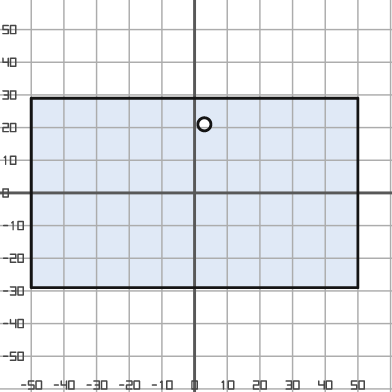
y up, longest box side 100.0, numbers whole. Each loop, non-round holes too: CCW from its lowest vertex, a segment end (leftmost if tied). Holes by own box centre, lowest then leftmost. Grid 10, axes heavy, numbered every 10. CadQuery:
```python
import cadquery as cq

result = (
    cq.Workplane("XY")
    .moveTo(-50.0, -29.0)
    .lineTo(50.0, -29.0)
    .lineTo(50.0, 29.0)
    .lineTo(-50.0, 29.0)
    .close()
    .moveTo(3.0, 21.0)
    .circle(2.0)
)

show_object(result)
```